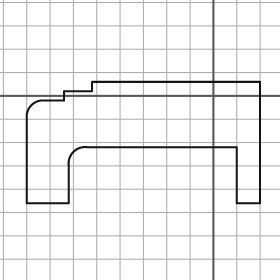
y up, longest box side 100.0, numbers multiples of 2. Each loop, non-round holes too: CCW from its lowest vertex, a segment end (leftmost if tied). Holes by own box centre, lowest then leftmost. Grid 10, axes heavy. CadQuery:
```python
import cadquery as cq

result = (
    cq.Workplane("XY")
    .moveTo(-80.0, -46.0)
    .lineTo(-62.0, -46.0)
    .lineTo(-62.0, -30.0)
    .threePointArc((-60.0, -24.0), (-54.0, -22.0))
    .lineTo(10.0, -22.0)
    .lineTo(10.0, -46.0)
    .lineTo(20.0, -46.0)
    .lineTo(20.0, 6.0)
    .lineTo(-52.0, 6.0)
    .lineTo(-52.0, 2.0)
    .lineTo(-64.0, 2.0)
    .lineTo(-64.0, -2.0)
    .lineTo(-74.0, -2.0)
    .threePointArc((-78.0, -4.0), (-80.0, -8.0))
    .close()
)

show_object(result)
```